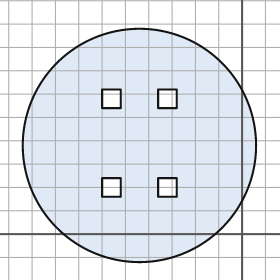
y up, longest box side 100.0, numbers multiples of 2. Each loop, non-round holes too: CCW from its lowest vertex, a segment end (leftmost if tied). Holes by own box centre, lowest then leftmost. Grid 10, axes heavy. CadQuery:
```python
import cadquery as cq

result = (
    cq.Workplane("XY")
    .moveTo(-44.0, 38.0)
    .circle(50.0)
    .moveTo(-60.0, 16.0)
    .lineTo(-52.0, 16.0)
    .lineTo(-52.0, 24.0)
    .lineTo(-60.0, 24.0)
    .close()
    .moveTo(-36.0, 16.0)
    .lineTo(-28.0, 16.0)
    .lineTo(-28.0, 24.0)
    .lineTo(-36.0, 24.0)
    .close()
    .moveTo(-60.0, 54.0)
    .lineTo(-52.0, 54.0)
    .lineTo(-52.0, 62.0)
    .lineTo(-60.0, 62.0)
    .close()
    .moveTo(-36.0, 54.0)
    .lineTo(-28.0, 54.0)
    .lineTo(-28.0, 62.0)
    .lineTo(-36.0, 62.0)
    .close()
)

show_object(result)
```